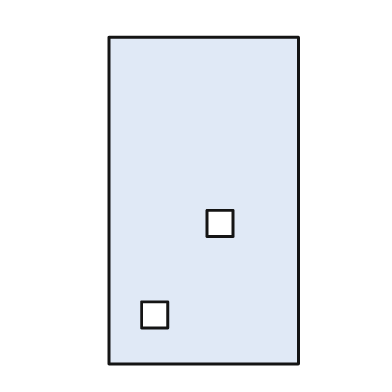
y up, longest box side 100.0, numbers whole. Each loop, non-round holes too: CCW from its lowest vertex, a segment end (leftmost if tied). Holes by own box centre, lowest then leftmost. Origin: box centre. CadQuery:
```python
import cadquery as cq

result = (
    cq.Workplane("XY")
    .moveTo(-29.0, -50.0)
    .lineTo(29.0, -50.0)
    .lineTo(29.0, 50.0)
    .lineTo(-29.0, 50.0)
    .close()
    .moveTo(-19.0, -39.0)
    .lineTo(-11.0, -39.0)
    .lineTo(-11.0, -31.0)
    .lineTo(-19.0, -31.0)
    .close()
    .moveTo(1.0, -11.0)
    .lineTo(9.0, -11.0)
    .lineTo(9.0, -3.0)
    .lineTo(1.0, -3.0)
    .close()
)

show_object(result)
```